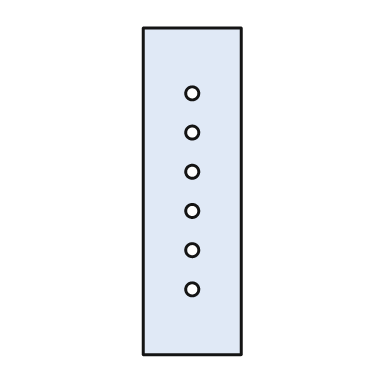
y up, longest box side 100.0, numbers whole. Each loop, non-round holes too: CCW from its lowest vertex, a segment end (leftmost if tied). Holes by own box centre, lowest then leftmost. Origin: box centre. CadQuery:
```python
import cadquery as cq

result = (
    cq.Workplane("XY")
    .moveTo(-15.0, -50.0)
    .lineTo(15.0, -50.0)
    .lineTo(15.0, 50.0)
    .lineTo(-15.0, 50.0)
    .close()
    .moveTo(0.0, -30.0)
    .circle(2.0)
    .moveTo(0.0, -18.0)
    .circle(2.0)
    .moveTo(0.0, -6.0)
    .circle(2.0)
    .moveTo(0.0, 6.0)
    .circle(2.0)
    .moveTo(0.0, 18.0)
    .circle(2.0)
    .moveTo(0.0, 30.0)
    .circle(2.0)
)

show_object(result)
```